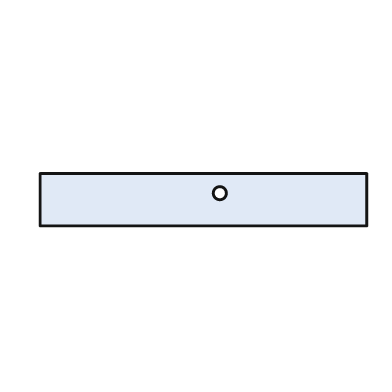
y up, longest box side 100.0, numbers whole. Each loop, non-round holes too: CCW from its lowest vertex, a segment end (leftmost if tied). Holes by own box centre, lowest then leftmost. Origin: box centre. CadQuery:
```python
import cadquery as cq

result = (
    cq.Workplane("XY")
    .moveTo(-50.0, -8.0)
    .lineTo(50.0, -8.0)
    .lineTo(50.0, 8.0)
    .lineTo(-50.0, 8.0)
    .close()
    .moveTo(5.0, 2.0)
    .circle(2.0)
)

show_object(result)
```